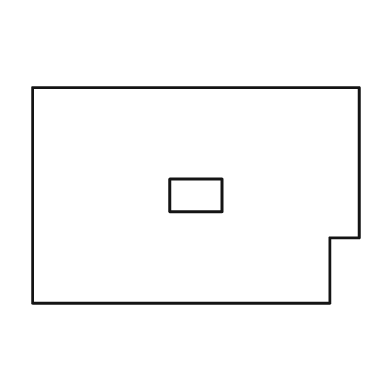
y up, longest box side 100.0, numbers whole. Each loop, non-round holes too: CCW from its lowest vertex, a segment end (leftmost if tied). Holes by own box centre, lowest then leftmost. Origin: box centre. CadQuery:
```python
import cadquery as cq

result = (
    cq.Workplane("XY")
    .moveTo(-50.0, -33.0)
    .lineTo(41.0, -33.0)
    .lineTo(41.0, -13.0)
    .lineTo(50.0, -13.0)
    .lineTo(50.0, 33.0)
    .lineTo(-50.0, 33.0)
    .close()
    .moveTo(-8.0, -5.0)
    .lineTo(8.0, -5.0)
    .lineTo(8.0, 5.0)
    .lineTo(-8.0, 5.0)
    .close()
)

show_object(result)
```